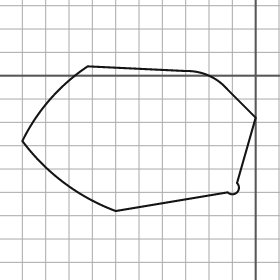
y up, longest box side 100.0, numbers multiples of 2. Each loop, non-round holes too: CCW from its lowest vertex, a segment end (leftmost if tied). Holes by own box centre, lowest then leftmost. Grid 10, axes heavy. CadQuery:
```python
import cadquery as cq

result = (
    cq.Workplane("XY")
    .moveTo(-60.0, -58.0)
    .lineTo(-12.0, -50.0)
    .threePointArc((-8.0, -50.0), (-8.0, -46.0))
    .lineTo(0.0, -18.0)
    .lineTo(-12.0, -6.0)
    .threePointArc((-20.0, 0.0), (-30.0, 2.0))
    .lineTo(-72.0, 4.0)
    .threePointArc((-88.0, -10.0), (-100.0, -28.0))
    .threePointArc((-82.0, -46.0), (-60.0, -58.0))
    .close()
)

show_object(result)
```